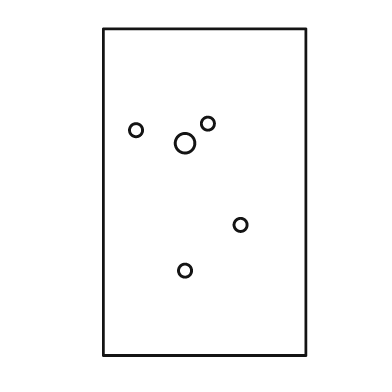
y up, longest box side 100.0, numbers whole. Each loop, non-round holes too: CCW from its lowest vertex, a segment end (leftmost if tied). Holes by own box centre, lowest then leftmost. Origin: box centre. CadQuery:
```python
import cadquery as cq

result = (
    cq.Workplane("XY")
    .moveTo(-31.0, -50.0)
    .lineTo(31.0, -50.0)
    .lineTo(31.0, 50.0)
    .lineTo(-31.0, 50.0)
    .close()
    .moveTo(-6.0, -24.0)
    .circle(2.0)
    .moveTo(11.0, -10.0)
    .circle(2.0)
    .moveTo(-6.0, 15.0)
    .circle(3.0)
    .moveTo(-21.0, 19.0)
    .circle(2.0)
    .moveTo(1.0, 21.0)
    .circle(2.0)
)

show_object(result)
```